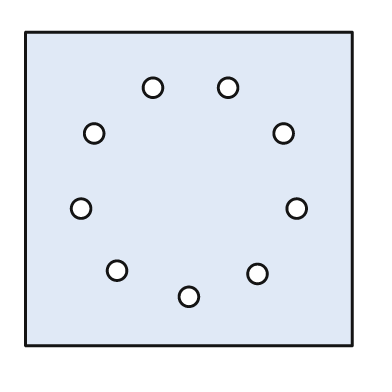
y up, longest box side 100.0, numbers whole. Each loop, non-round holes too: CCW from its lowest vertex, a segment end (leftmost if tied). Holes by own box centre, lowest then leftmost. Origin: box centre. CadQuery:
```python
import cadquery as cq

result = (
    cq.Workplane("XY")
    .moveTo(-50.0, -48.0)
    .lineTo(50.0, -48.0)
    .lineTo(50.0, 48.0)
    .lineTo(-50.0, 48.0)
    .close()
    .moveTo(0.0, -33.0)
    .circle(3.0)
    .moveTo(21.0, -26.0)
    .circle(3.0)
    .moveTo(-22.0, -25.0)
    .circle(3.0)
    .moveTo(-33.0, -6.0)
    .circle(3.0)
    .moveTo(33.0, -6.0)
    .circle(3.0)
    .moveTo(-29.0, 17.0)
    .circle(3.0)
    .moveTo(29.0, 17.0)
    .circle(3.0)
    .moveTo(-11.0, 31.0)
    .circle(3.0)
    .moveTo(12.0, 31.0)
    .circle(3.0)
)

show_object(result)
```